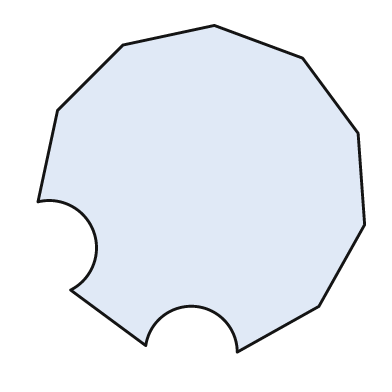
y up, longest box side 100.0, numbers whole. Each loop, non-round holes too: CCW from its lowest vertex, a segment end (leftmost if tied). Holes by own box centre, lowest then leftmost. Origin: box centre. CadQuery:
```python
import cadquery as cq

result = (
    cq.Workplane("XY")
    .moveTo(11.0, -50.0)
    .lineTo(36.0, -36.0)
    .lineTo(50.0, -11.0)
    .lineTo(48.0, 17.0)
    .lineTo(31.0, 40.0)
    .lineTo(4.0, 50.0)
    .lineTo(-24.0, 44.0)
    .lineTo(-44.0, 24.0)
    .lineTo(-50.0, -4.0)
    .threePointArc((-33.0, -13.0), (-40.0, -31.0))
    .lineTo(-17.0, -48.0)
    .threePointArc((-2.0, -36.0), (11.0, -50.0))
    .close()
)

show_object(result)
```